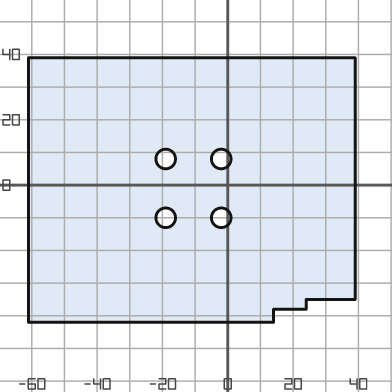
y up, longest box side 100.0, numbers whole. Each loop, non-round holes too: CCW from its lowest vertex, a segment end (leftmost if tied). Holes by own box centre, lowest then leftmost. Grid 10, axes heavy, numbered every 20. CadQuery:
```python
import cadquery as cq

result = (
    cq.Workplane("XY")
    .moveTo(-61.0, -42.0)
    .lineTo(14.0, -42.0)
    .lineTo(14.0, -38.0)
    .lineTo(24.0, -38.0)
    .lineTo(24.0, -35.0)
    .lineTo(39.0, -35.0)
    .lineTo(39.0, 39.0)
    .lineTo(-61.0, 39.0)
    .close()
    .moveTo(-19.0, -10.0)
    .circle(3.0)
    .moveTo(-2.0, -10.0)
    .circle(3.0)
    .moveTo(-19.0, 8.0)
    .circle(3.0)
    .moveTo(-2.0, 8.0)
    .circle(3.0)
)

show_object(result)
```